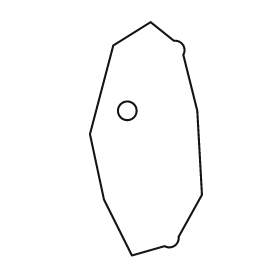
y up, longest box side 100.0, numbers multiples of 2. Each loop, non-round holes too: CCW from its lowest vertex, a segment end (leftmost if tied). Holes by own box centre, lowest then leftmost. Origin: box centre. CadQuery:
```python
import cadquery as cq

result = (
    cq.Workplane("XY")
    .moveTo(-6.0, -50.0)
    .lineTo(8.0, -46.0)
    .threePointArc((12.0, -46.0), (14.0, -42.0))
    .lineTo(24.0, -24.0)
    .lineTo(22.0, 12.0)
    .lineTo(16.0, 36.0)
    .threePointArc((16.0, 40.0), (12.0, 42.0))
    .lineTo(2.0, 50.0)
    .lineTo(-14.0, 40.0)
    .lineTo(-24.0, 2.0)
    .lineTo(-18.0, -26.0)
    .close()
    .moveTo(-8.0, 12.0)
    .circle(4.0)
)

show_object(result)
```